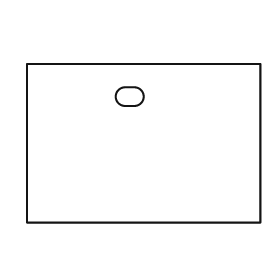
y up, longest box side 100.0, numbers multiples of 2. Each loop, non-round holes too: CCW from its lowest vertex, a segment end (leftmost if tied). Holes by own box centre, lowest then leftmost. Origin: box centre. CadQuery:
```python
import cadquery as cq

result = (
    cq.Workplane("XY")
    .moveTo(-50.0, -34.0)
    .lineTo(50.0, -34.0)
    .lineTo(50.0, 34.0)
    .lineTo(-50.0, 34.0)
    .close()
    .moveTo(-8.0, 16.0)
    .lineTo(-4.0, 16.0)
    .threePointArc((0.0, 20.0), (-4.0, 24.0))
    .lineTo(-8.0, 24.0)
    .threePointArc((-12.0, 20.0), (-8.0, 16.0))
    .close()
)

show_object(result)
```